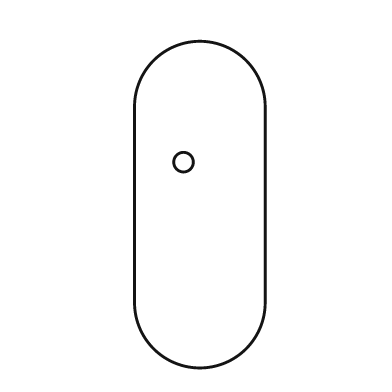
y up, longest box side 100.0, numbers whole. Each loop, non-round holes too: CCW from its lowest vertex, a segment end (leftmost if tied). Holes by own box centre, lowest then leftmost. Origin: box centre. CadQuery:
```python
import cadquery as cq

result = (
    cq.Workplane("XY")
    .moveTo(-20.0, -30.0)
    .threePointArc((0.0, -50.0), (20.0, -30.0))
    .lineTo(20.0, 30.0)
    .threePointArc((0.0, 50.0), (-20.0, 30.0))
    .close()
    .moveTo(-5.0, 13.0)
    .circle(3.0)
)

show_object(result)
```